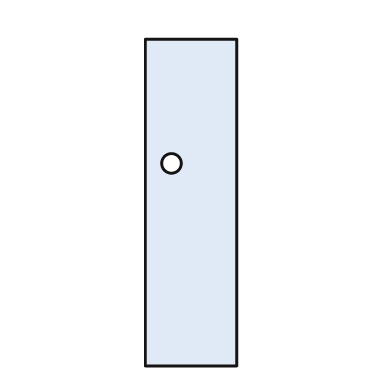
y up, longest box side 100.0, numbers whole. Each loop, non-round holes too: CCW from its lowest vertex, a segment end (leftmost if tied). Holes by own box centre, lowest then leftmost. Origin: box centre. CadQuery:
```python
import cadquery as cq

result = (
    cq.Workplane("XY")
    .moveTo(-14.0, -50.0)
    .lineTo(14.0, -50.0)
    .lineTo(14.0, 50.0)
    .lineTo(-14.0, 50.0)
    .close()
    .moveTo(-6.0, 12.0)
    .circle(3.0)
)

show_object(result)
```